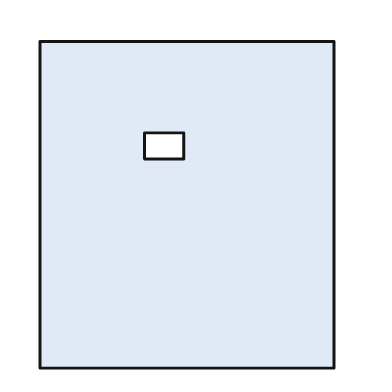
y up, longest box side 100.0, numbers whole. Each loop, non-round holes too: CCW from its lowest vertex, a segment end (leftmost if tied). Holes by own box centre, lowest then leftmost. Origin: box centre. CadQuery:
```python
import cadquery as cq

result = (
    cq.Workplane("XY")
    .moveTo(-45.0, -50.0)
    .lineTo(45.0, -50.0)
    .lineTo(45.0, 50.0)
    .lineTo(-45.0, 50.0)
    .close()
    .moveTo(-13.0, 14.0)
    .lineTo(-1.0, 14.0)
    .lineTo(-1.0, 22.0)
    .lineTo(-13.0, 22.0)
    .close()
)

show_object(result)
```